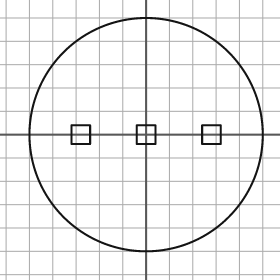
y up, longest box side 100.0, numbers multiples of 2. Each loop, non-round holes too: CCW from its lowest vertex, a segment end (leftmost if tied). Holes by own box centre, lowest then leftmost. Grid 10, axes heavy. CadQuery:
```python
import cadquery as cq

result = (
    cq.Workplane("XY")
    .moveTo(0.0, 0.0)
    .circle(50.0)
    .moveTo(-32.0, -4.0)
    .lineTo(-24.0, -4.0)
    .lineTo(-24.0, 4.0)
    .lineTo(-32.0, 4.0)
    .close()
    .moveTo(-4.0, -4.0)
    .lineTo(4.0, -4.0)
    .lineTo(4.0, 4.0)
    .lineTo(-4.0, 4.0)
    .close()
    .moveTo(24.0, -4.0)
    .lineTo(32.0, -4.0)
    .lineTo(32.0, 4.0)
    .lineTo(24.0, 4.0)
    .close()
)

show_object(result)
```